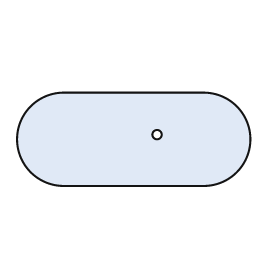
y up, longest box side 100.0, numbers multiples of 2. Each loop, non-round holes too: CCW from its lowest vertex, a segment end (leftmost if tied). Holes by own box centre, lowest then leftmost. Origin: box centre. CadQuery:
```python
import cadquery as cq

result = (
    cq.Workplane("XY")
    .moveTo(-30.0, -20.0)
    .lineTo(30.0, -20.0)
    .threePointArc((50.0, 0.0), (30.0, 20.0))
    .lineTo(-30.0, 20.0)
    .threePointArc((-50.0, 0.0), (-30.0, -20.0))
    .close()
    .moveTo(10.0, 2.0)
    .circle(2.0)
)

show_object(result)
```